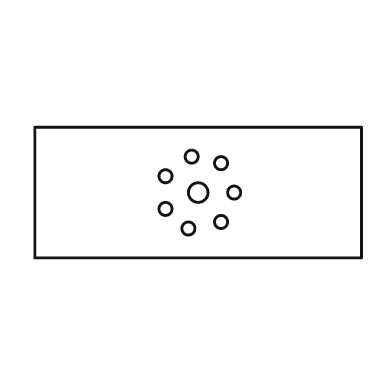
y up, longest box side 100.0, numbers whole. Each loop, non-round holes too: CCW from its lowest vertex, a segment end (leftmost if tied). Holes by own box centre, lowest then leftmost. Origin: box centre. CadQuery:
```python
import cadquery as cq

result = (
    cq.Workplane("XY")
    .moveTo(-50.0, -20.0)
    .lineTo(50.0, -20.0)
    .lineTo(50.0, 20.0)
    .lineTo(-50.0, 20.0)
    .close()
    .moveTo(-3.0, -11.0)
    .circle(2.0)
    .moveTo(7.0, -9.0)
    .circle(2.0)
    .moveTo(-10.0, -5.0)
    .circle(2.0)
    .moveTo(0.0, 0.0)
    .circle(3.0)
    .moveTo(11.0, 0.0)
    .circle(2.0)
    .moveTo(-10.0, 5.0)
    .circle(2.0)
    .moveTo(7.0, 9.0)
    .circle(2.0)
    .moveTo(-2.0, 11.0)
    .circle(2.0)
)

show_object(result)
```